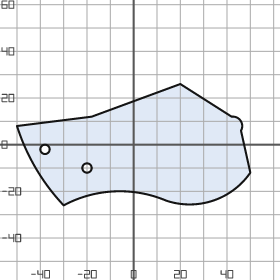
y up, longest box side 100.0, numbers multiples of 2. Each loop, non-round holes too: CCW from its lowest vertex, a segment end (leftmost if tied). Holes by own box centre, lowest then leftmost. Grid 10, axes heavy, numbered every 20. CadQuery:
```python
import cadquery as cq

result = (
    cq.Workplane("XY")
    .moveTo(-30.0, -26.0)
    .threePointArc((-8.0, -20.0), (14.0, -24.0))
    .threePointArc((34.0, -24.0), (50.0, -12.0))
    .lineTo(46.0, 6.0)
    .threePointArc((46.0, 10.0), (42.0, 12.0))
    .lineTo(20.0, 26.0)
    .lineTo(-18.0, 12.0)
    .lineTo(-50.0, 8.0)
    .threePointArc((-42.0, -10.0), (-30.0, -26.0))
    .close()
    .moveTo(-20.0, -10.0)
    .circle(2.0)
    .moveTo(-38.0, -2.0)
    .circle(2.0)
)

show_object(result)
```